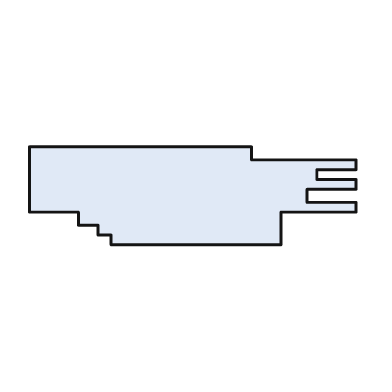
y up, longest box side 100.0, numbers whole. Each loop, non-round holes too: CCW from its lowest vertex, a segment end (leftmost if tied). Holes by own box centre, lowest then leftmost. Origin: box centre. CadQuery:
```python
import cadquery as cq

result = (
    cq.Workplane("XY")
    .moveTo(-25.0, -15.0)
    .lineTo(27.0, -15.0)
    .lineTo(27.0, -5.0)
    .lineTo(50.0, -5.0)
    .lineTo(50.0, -2.0)
    .lineTo(35.0, -2.0)
    .lineTo(35.0, 2.0)
    .lineTo(50.0, 2.0)
    .lineTo(50.0, 5.0)
    .lineTo(38.0, 5.0)
    .lineTo(38.0, 8.0)
    .lineTo(50.0, 8.0)
    .lineTo(50.0, 11.0)
    .lineTo(18.0, 11.0)
    .lineTo(18.0, 15.0)
    .lineTo(-50.0, 15.0)
    .lineTo(-50.0, -5.0)
    .lineTo(-35.0, -5.0)
    .lineTo(-35.0, -9.0)
    .lineTo(-29.0, -9.0)
    .lineTo(-29.0, -12.0)
    .lineTo(-25.0, -12.0)
    .close()
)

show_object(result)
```